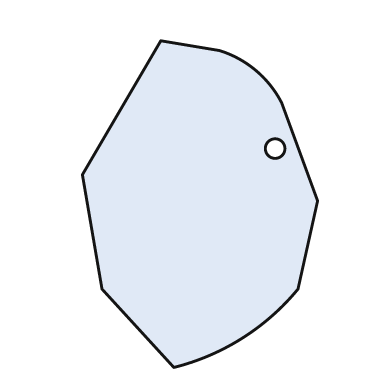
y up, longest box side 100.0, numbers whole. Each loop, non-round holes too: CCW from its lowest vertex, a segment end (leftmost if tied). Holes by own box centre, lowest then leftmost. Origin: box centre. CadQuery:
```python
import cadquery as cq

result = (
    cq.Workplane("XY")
    .moveTo(-8.0, -50.0)
    .threePointArc((13.0, -41.0), (30.0, -26.0))
    .lineTo(36.0, 1.0)
    .lineTo(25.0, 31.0)
    .threePointArc((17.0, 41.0), (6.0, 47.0))
    .lineTo(-12.0, 50.0)
    .lineTo(-36.0, 9.0)
    .lineTo(-30.0, -26.0)
    .close()
    .moveTo(23.0, 17.0)
    .circle(3.0)
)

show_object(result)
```